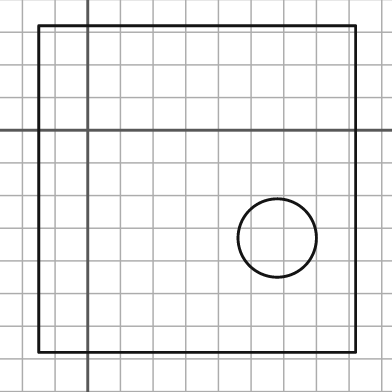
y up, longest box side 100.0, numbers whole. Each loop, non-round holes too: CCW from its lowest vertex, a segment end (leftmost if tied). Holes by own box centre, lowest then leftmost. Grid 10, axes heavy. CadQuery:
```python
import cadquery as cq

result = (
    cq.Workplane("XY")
    .moveTo(-15.0, -68.0)
    .lineTo(82.0, -68.0)
    .lineTo(82.0, 32.0)
    .lineTo(-15.0, 32.0)
    .close()
    .moveTo(58.0, -33.0)
    .circle(12.0)
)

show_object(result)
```